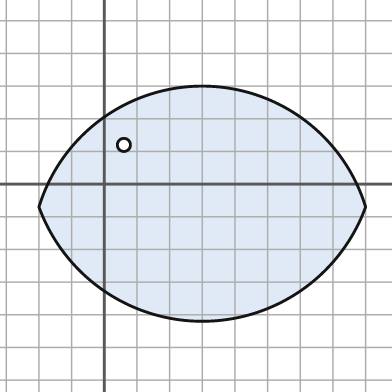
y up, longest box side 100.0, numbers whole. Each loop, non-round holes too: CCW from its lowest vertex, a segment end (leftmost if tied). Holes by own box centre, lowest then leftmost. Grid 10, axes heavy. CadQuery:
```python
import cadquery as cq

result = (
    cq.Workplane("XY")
    .moveTo(-20.0, -7.0)
    .threePointArc((30.0, -42.0), (80.0, -7.0))
    .threePointArc((30.0, 30.0), (-20.0, -7.0))
    .close()
    .moveTo(6.0, 12.0)
    .circle(2.0)
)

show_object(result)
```